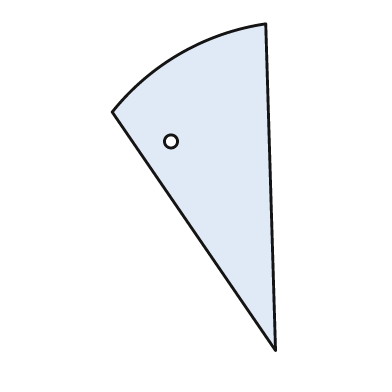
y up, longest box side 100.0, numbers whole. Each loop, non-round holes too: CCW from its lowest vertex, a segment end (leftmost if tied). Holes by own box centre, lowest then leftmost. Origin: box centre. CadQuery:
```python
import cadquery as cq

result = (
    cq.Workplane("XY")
    .moveTo(25.0, -50.0)
    .lineTo(22.0, 50.0)
    .threePointArc((-4.0, 41.0), (-25.0, 23.0))
    .close()
    .moveTo(-7.0, 14.0)
    .circle(2.0)
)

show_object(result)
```